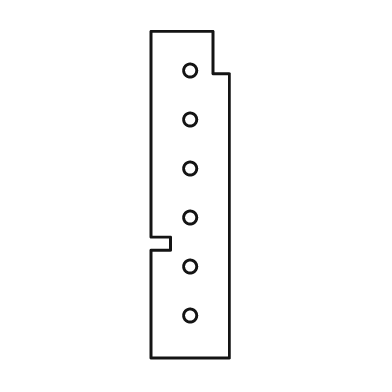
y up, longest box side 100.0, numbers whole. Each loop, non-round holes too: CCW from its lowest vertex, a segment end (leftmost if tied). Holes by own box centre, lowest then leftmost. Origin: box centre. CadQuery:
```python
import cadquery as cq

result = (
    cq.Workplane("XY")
    .moveTo(-12.0, -50.0)
    .lineTo(12.0, -50.0)
    .lineTo(12.0, 37.0)
    .lineTo(7.0, 37.0)
    .lineTo(7.0, 50.0)
    .lineTo(-12.0, 50.0)
    .lineTo(-12.0, -13.0)
    .lineTo(-6.0, -13.0)
    .lineTo(-6.0, -17.0)
    .lineTo(-12.0, -17.0)
    .close()
    .moveTo(0.0, -37.0)
    .circle(2.0)
    .moveTo(0.0, -22.0)
    .circle(2.0)
    .moveTo(0.0, -7.0)
    .circle(2.0)
    .moveTo(0.0, 8.0)
    .circle(2.0)
    .moveTo(0.0, 23.0)
    .circle(2.0)
    .moveTo(0.0, 38.0)
    .circle(2.0)
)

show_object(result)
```